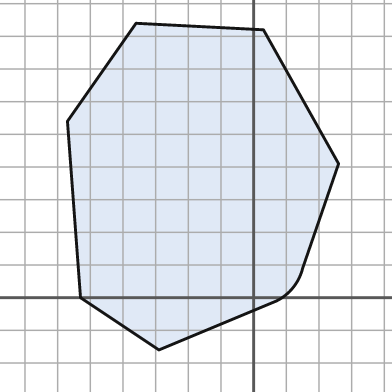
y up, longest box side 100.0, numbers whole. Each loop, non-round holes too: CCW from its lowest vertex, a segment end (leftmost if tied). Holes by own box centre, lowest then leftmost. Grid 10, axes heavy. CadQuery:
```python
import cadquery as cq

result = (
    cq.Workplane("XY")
    .moveTo(-29.0, -16.0)
    .lineTo(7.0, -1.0)
    .threePointArc((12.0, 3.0), (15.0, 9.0))
    .lineTo(26.0, 41.0)
    .lineTo(3.0, 82.0)
    .lineTo(-36.0, 84.0)
    .lineTo(-57.0, 54.0)
    .lineTo(-53.0, 0.0)
    .close()
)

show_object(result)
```